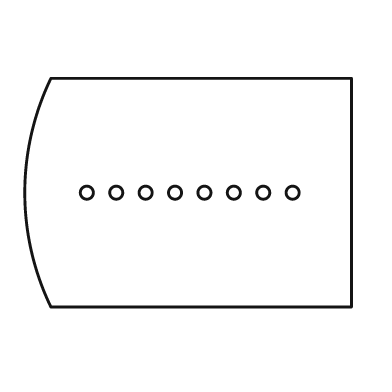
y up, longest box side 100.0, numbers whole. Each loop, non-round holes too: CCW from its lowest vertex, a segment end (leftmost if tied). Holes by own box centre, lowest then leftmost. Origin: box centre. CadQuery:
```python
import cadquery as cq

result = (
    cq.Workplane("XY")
    .moveTo(-42.0, -35.0)
    .lineTo(50.0, -35.0)
    .lineTo(50.0, 35.0)
    .lineTo(-42.0, 35.0)
    .threePointArc((-50.0, 0.0), (-42.0, -35.0))
    .close()
    .moveTo(-31.0, 0.0)
    .circle(2.0)
    .moveTo(-22.0, 0.0)
    .circle(2.0)
    .moveTo(-13.0, 0.0)
    .circle(2.0)
    .moveTo(-4.0, 0.0)
    .circle(2.0)
    .moveTo(5.0, 0.0)
    .circle(2.0)
    .moveTo(14.0, 0.0)
    .circle(2.0)
    .moveTo(23.0, 0.0)
    .circle(2.0)
    .moveTo(32.0, 0.0)
    .circle(2.0)
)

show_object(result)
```